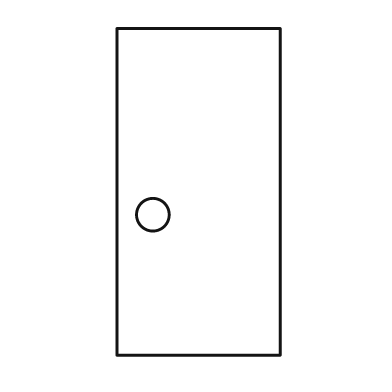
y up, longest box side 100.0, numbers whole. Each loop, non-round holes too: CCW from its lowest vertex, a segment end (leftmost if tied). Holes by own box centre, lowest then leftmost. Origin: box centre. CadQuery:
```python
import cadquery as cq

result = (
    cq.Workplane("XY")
    .moveTo(-25.0, -50.0)
    .lineTo(25.0, -50.0)
    .lineTo(25.0, 50.0)
    .lineTo(-25.0, 50.0)
    .close()
    .moveTo(-14.0, -7.0)
    .circle(5.0)
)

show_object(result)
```